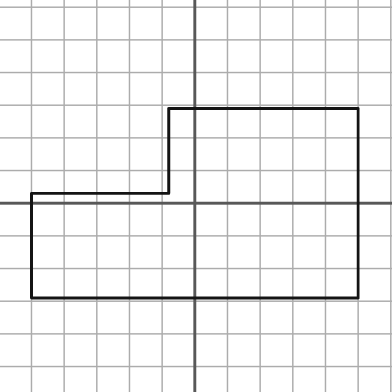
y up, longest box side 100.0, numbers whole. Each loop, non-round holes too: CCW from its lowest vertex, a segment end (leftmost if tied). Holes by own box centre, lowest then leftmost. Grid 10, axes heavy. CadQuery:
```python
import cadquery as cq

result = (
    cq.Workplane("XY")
    .moveTo(-50.0, -29.0)
    .lineTo(50.0, -29.0)
    .lineTo(50.0, 29.0)
    .lineTo(-8.0, 29.0)
    .lineTo(-8.0, 3.0)
    .lineTo(-50.0, 3.0)
    .close()
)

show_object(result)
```